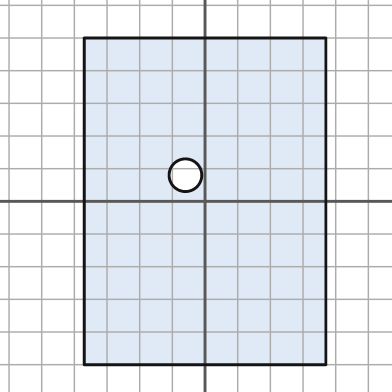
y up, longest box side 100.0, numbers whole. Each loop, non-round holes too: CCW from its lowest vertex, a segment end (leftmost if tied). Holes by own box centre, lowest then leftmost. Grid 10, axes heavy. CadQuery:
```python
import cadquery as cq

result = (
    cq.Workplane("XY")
    .moveTo(-37.0, -50.0)
    .lineTo(37.0, -50.0)
    .lineTo(37.0, 50.0)
    .lineTo(-37.0, 50.0)
    .close()
    .moveTo(-6.0, 8.0)
    .circle(5.0)
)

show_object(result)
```